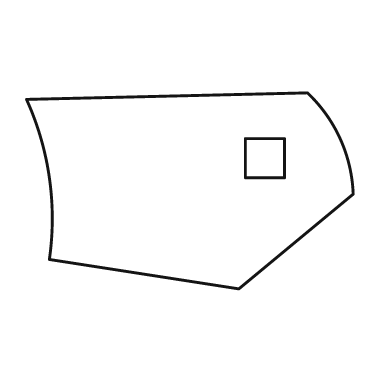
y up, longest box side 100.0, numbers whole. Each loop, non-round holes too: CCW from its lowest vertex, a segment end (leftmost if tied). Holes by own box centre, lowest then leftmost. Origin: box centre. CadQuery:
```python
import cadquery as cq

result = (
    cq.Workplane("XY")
    .moveTo(15.0, -30.0)
    .lineTo(50.0, -1.0)
    .threePointArc((46.0, 16.0), (36.0, 30.0))
    .lineTo(-50.0, 28.0)
    .threePointArc((-43.0, 4.0), (-43.0, -21.0))
    .close()
    .moveTo(17.0, 4.0)
    .lineTo(29.0, 4.0)
    .lineTo(29.0, 16.0)
    .lineTo(17.0, 16.0)
    .close()
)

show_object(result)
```